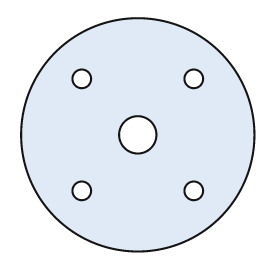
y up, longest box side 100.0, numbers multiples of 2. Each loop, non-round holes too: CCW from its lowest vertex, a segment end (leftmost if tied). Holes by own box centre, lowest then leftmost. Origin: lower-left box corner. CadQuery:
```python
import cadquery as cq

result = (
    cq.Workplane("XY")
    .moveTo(50.0, 50.0)
    .circle(50.0)
    .moveTo(26.0, 26.0)
    .circle(4.0)
    .moveTo(74.0, 26.0)
    .circle(4.0)
    .moveTo(50.0, 50.0)
    .circle(8.0)
    .moveTo(26.0, 74.0)
    .circle(4.0)
    .moveTo(74.0, 74.0)
    .circle(4.0)
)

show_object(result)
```